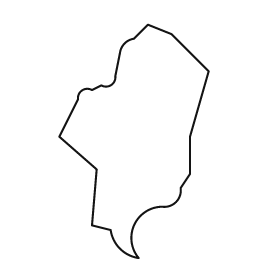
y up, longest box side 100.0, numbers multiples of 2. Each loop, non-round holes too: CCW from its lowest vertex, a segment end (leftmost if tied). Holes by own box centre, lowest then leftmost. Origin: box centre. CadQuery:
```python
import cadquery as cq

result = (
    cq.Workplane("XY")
    .moveTo(2.0, -50.0)
    .threePointArc((0.0, -36.0), (12.0, -28.0))
    .threePointArc((18.0, -26.0), (20.0, -20.0))
    .lineTo(24.0, -14.0)
    .lineTo(24.0, 2.0)
    .lineTo(32.0, 30.0)
    .lineTo(16.0, 46.0)
    .lineTo(6.0, 50.0)
    .lineTo(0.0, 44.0)
    .threePointArc((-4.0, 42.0), (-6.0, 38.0))
    .lineTo(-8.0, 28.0)
    .threePointArc((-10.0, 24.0), (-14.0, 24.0))
    .lineTo(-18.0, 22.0)
    .threePointArc((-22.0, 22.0), (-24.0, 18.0))
    .lineTo(-32.0, 2.0)
    .lineTo(-16.0, -12.0)
    .lineTo(-18.0, -36.0)
    .lineTo(-10.0, -38.0)
    .threePointArc((-6.0, -46.0), (2.0, -50.0))
    .close()
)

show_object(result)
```